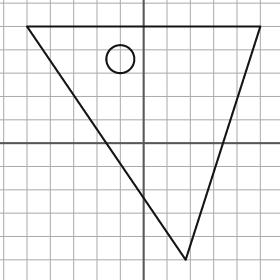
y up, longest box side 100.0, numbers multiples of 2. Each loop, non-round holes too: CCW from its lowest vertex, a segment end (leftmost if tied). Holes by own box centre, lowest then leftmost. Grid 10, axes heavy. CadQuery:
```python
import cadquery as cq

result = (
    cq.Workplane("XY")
    .moveTo(18.0, -50.0)
    .lineTo(50.0, 50.0)
    .lineTo(-50.0, 50.0)
    .close()
    .moveTo(-10.0, 36.0)
    .circle(6.0)
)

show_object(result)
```